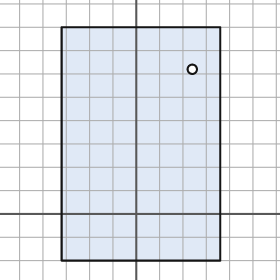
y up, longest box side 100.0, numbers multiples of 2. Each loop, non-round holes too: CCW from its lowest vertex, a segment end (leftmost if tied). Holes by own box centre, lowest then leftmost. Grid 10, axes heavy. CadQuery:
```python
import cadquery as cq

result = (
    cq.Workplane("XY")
    .moveTo(-32.0, -20.0)
    .lineTo(36.0, -20.0)
    .lineTo(36.0, 80.0)
    .lineTo(-32.0, 80.0)
    .close()
    .moveTo(24.0, 62.0)
    .circle(2.0)
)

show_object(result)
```